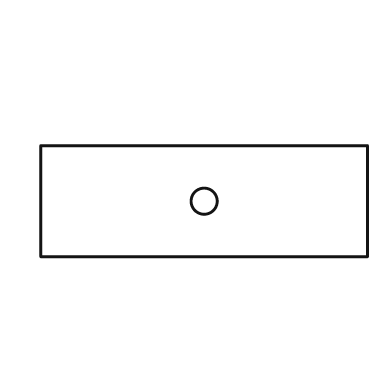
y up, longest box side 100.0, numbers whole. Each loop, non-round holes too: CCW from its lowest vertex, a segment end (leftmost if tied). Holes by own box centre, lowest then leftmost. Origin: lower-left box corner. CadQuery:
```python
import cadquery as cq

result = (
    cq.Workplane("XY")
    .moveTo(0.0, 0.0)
    .lineTo(100.0, 0.0)
    .lineTo(100.0, 34.0)
    .lineTo(0.0, 34.0)
    .close()
    .moveTo(50.0, 17.0)
    .circle(4.0)
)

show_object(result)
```